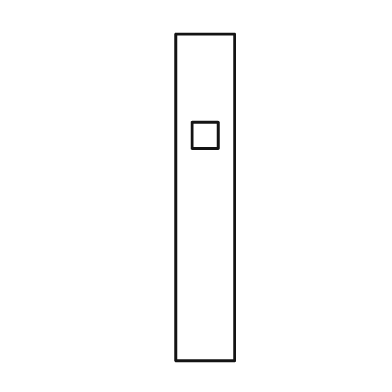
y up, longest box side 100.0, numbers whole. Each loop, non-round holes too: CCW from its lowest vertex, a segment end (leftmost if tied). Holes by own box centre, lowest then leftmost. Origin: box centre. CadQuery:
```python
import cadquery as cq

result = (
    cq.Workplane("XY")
    .moveTo(-9.0, -50.0)
    .lineTo(9.0, -50.0)
    .lineTo(9.0, 50.0)
    .lineTo(-9.0, 50.0)
    .close()
    .moveTo(-4.0, 15.0)
    .lineTo(4.0, 15.0)
    .lineTo(4.0, 23.0)
    .lineTo(-4.0, 23.0)
    .close()
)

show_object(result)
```